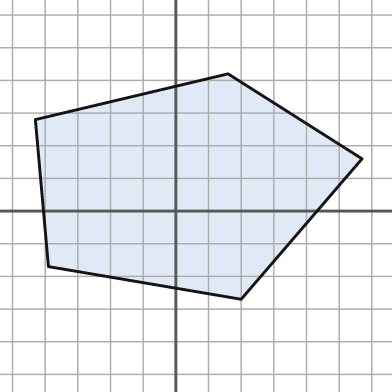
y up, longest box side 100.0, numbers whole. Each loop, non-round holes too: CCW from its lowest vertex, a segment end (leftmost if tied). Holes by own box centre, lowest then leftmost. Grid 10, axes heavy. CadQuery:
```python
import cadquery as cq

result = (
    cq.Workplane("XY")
    .moveTo(20.0, -27.0)
    .lineTo(57.0, 16.0)
    .lineTo(16.0, 42.0)
    .lineTo(-43.0, 28.0)
    .lineTo(-39.0, -17.0)
    .close()
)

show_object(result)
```